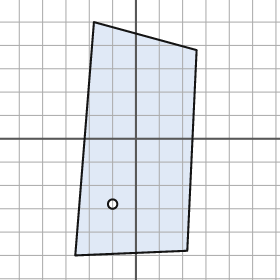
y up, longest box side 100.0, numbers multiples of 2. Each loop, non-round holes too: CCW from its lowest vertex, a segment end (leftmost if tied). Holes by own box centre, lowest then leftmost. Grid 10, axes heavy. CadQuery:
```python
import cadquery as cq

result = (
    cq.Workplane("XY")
    .moveTo(-26.0, -50.0)
    .lineTo(22.0, -48.0)
    .lineTo(26.0, 38.0)
    .lineTo(-18.0, 50.0)
    .close()
    .moveTo(-10.0, -28.0)
    .circle(2.0)
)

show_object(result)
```